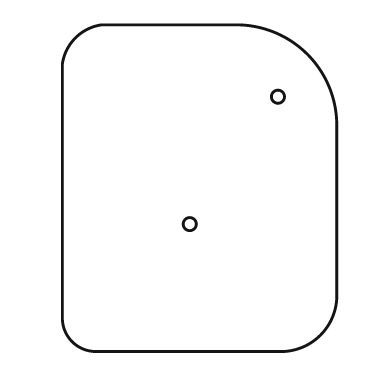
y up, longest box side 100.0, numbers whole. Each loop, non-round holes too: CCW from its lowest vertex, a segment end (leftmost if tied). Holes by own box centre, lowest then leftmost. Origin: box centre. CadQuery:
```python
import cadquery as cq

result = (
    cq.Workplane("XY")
    .moveTo(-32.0, -50.0)
    .lineTo(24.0, -50.0)
    .threePointArc((37.0, -45.0), (42.0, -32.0))
    .lineTo(42.0, 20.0)
    .threePointArc((33.0, 41.0), (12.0, 50.0))
    .lineTo(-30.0, 50.0)
    .threePointArc((-38.0, 46.0), (-42.0, 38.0))
    .lineTo(-42.0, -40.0)
    .threePointArc((-39.0, -47.0), (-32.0, -50.0))
    .close()
    .moveTo(-3.0, -11.0)
    .circle(2.0)
    .moveTo(24.0, 28.0)
    .circle(2.0)
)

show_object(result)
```